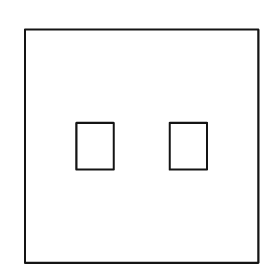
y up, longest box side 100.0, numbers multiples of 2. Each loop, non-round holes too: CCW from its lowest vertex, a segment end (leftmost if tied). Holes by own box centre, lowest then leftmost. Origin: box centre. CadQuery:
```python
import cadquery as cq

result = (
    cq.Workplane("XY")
    .moveTo(-50.0, -50.0)
    .lineTo(50.0, -50.0)
    .lineTo(50.0, 50.0)
    .lineTo(-50.0, 50.0)
    .close()
    .moveTo(-28.0, -10.0)
    .lineTo(-12.0, -10.0)
    .lineTo(-12.0, 10.0)
    .lineTo(-28.0, 10.0)
    .close()
    .moveTo(12.0, -10.0)
    .lineTo(28.0, -10.0)
    .lineTo(28.0, 10.0)
    .lineTo(12.0, 10.0)
    .close()
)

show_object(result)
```